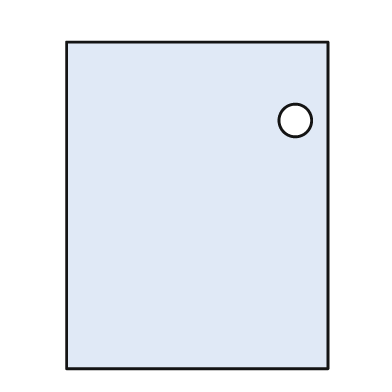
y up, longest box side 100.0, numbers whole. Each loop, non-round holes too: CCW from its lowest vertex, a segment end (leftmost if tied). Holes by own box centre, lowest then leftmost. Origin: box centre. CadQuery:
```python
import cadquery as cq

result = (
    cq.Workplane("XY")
    .moveTo(-40.0, -50.0)
    .lineTo(40.0, -50.0)
    .lineTo(40.0, 50.0)
    .lineTo(-40.0, 50.0)
    .close()
    .moveTo(30.0, 26.0)
    .circle(5.0)
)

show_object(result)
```